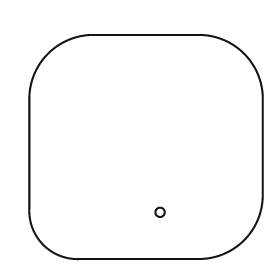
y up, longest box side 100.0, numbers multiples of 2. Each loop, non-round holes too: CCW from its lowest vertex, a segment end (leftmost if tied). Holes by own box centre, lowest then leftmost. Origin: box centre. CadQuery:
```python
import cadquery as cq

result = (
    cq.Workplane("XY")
    .moveTo(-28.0, -48.0)
    .lineTo(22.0, -48.0)
    .threePointArc((42.0, -40.0), (50.0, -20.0))
    .lineTo(50.0, 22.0)
    .threePointArc((42.0, 40.0), (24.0, 48.0))
    .lineTo(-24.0, 48.0)
    .threePointArc((-42.0, 40.0), (-50.0, 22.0))
    .lineTo(-50.0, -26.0)
    .threePointArc((-44.0, -42.0), (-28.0, -48.0))
    .close()
    .moveTo(6.0, -28.0)
    .circle(2.0)
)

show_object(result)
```